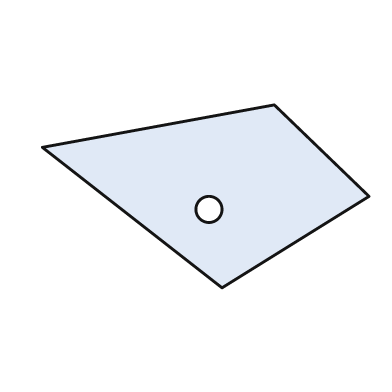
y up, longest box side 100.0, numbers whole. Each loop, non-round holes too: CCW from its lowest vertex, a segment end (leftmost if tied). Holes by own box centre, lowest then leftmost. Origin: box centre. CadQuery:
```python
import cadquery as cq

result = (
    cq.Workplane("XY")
    .moveTo(5.0, -28.0)
    .lineTo(50.0, 0.0)
    .lineTo(21.0, 28.0)
    .lineTo(-50.0, 15.0)
    .close()
    .moveTo(1.0, -4.0)
    .circle(4.0)
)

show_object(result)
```